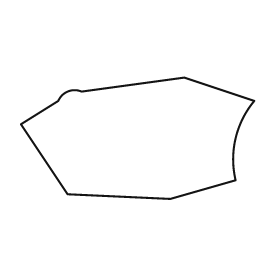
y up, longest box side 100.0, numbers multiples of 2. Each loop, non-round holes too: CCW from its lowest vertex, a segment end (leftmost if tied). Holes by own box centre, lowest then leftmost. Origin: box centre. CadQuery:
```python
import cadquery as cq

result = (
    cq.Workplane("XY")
    .moveTo(14.0, -26.0)
    .lineTo(42.0, -18.0)
    .threePointArc((42.0, 0.0), (50.0, 16.0))
    .lineTo(20.0, 26.0)
    .lineTo(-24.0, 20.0)
    .threePointArc((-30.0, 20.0), (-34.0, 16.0))
    .lineTo(-50.0, 6.0)
    .lineTo(-30.0, -24.0)
    .close()
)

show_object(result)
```